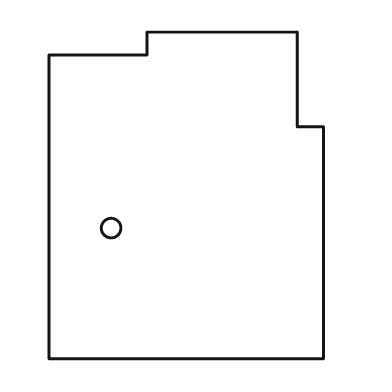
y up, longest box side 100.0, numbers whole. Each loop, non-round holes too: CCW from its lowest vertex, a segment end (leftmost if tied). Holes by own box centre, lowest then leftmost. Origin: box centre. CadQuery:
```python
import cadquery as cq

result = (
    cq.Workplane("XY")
    .moveTo(-42.0, -50.0)
    .lineTo(42.0, -50.0)
    .lineTo(42.0, 21.0)
    .lineTo(34.0, 21.0)
    .lineTo(34.0, 50.0)
    .lineTo(-12.0, 50.0)
    .lineTo(-12.0, 43.0)
    .lineTo(-42.0, 43.0)
    .close()
    .moveTo(-23.0, -10.0)
    .circle(3.0)
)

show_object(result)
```